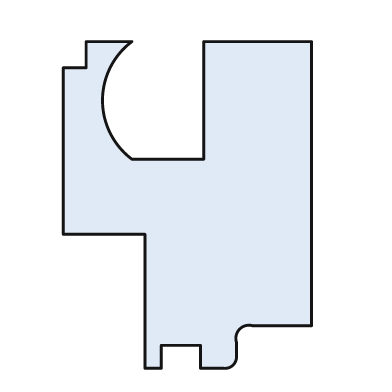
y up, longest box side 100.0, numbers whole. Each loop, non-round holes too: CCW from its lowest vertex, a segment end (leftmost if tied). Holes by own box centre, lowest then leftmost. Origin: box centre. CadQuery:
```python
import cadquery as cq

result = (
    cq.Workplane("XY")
    .moveTo(-13.0, -50.0)
    .lineTo(-8.0, -50.0)
    .lineTo(-8.0, -43.0)
    .lineTo(4.0, -43.0)
    .lineTo(4.0, -50.0)
    .lineTo(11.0, -50.0)
    .threePointArc((14.0, -49.0), (15.0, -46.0))
    .lineTo(15.0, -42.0)
    .threePointArc((16.0, -38.0), (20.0, -37.0))
    .lineTo(38.0, -37.0)
    .lineTo(38.0, 50.0)
    .lineTo(5.0, 50.0)
    .lineTo(5.0, 14.0)
    .lineTo(-17.0, 14.0)
    .threePointArc((-26.0, 32.0), (-17.0, 50.0))
    .lineTo(-31.0, 50.0)
    .lineTo(-31.0, 42.0)
    .lineTo(-38.0, 42.0)
    .lineTo(-38.0, -9.0)
    .lineTo(-13.0, -9.0)
    .close()
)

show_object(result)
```